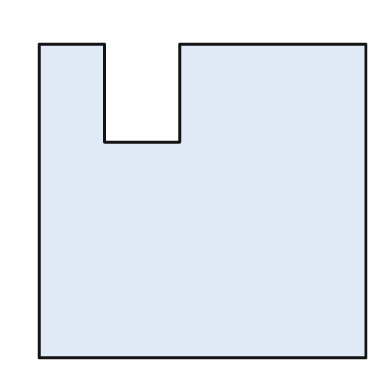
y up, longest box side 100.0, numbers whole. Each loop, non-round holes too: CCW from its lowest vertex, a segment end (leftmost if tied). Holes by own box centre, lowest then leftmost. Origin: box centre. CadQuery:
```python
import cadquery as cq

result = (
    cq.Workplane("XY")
    .moveTo(-50.0, -48.0)
    .lineTo(50.0, -48.0)
    .lineTo(50.0, 48.0)
    .lineTo(-7.0, 48.0)
    .lineTo(-7.0, 18.0)
    .lineTo(-30.0, 18.0)
    .lineTo(-30.0, 48.0)
    .lineTo(-50.0, 48.0)
    .close()
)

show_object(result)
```